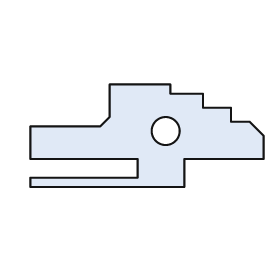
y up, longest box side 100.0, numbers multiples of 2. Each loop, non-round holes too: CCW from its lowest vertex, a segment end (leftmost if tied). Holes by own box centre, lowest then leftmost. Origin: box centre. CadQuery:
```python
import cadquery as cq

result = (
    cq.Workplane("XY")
    .moveTo(-50.0, -22.0)
    .lineTo(16.0, -22.0)
    .lineTo(16.0, -10.0)
    .lineTo(50.0, -10.0)
    .lineTo(50.0, 0.0)
    .lineTo(44.0, 6.0)
    .lineTo(36.0, 6.0)
    .lineTo(36.0, 12.0)
    .lineTo(24.0, 12.0)
    .lineTo(24.0, 18.0)
    .lineTo(10.0, 18.0)
    .lineTo(10.0, 22.0)
    .lineTo(-16.0, 22.0)
    .lineTo(-16.0, 8.0)
    .lineTo(-20.0, 4.0)
    .lineTo(-50.0, 4.0)
    .lineTo(-50.0, -10.0)
    .lineTo(-4.0, -10.0)
    .lineTo(-4.0, -18.0)
    .lineTo(-50.0, -18.0)
    .close()
    .moveTo(8.0, 2.0)
    .circle(6.0)
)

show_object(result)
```